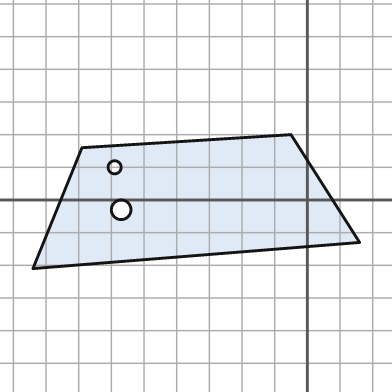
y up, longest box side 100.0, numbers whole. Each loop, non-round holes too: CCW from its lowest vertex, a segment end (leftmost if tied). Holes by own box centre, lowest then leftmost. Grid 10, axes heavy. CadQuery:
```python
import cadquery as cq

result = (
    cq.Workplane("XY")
    .moveTo(-84.0, -21.0)
    .lineTo(16.0, -13.0)
    .lineTo(-5.0, 20.0)
    .lineTo(-69.0, 16.0)
    .close()
    .moveTo(-57.0, -3.0)
    .circle(3.0)
    .moveTo(-59.0, 10.0)
    .circle(2.0)
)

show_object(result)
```